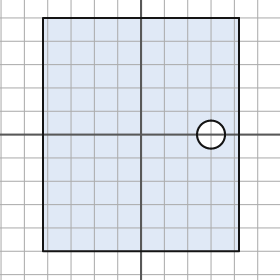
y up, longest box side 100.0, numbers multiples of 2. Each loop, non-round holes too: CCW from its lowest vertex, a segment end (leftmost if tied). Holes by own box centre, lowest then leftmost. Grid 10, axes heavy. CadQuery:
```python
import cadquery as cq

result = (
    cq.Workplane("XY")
    .moveTo(-42.0, -50.0)
    .lineTo(42.0, -50.0)
    .lineTo(42.0, 50.0)
    .lineTo(-42.0, 50.0)
    .close()
    .moveTo(30.0, 0.0)
    .circle(6.0)
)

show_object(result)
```